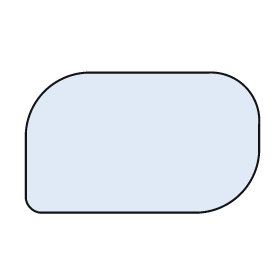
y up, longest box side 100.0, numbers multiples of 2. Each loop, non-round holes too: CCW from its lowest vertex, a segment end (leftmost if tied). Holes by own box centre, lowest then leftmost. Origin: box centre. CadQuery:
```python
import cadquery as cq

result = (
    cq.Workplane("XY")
    .moveTo(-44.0, -30.0)
    .lineTo(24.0, -30.0)
    .threePointArc((42.0, -22.0), (50.0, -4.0))
    .lineTo(50.0, 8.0)
    .threePointArc((44.0, 24.0), (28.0, 30.0))
    .lineTo(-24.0, 30.0)
    .threePointArc((-42.0, 22.0), (-50.0, 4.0))
    .lineTo(-50.0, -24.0)
    .threePointArc((-48.0, -28.0), (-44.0, -30.0))
    .close()
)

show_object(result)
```